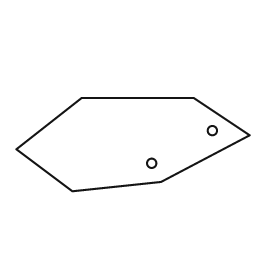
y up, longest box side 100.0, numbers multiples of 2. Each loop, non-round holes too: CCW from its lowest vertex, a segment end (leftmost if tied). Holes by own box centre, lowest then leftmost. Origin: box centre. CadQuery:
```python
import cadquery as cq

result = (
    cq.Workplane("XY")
    .moveTo(-26.0, -20.0)
    .lineTo(12.0, -16.0)
    .lineTo(50.0, 4.0)
    .lineTo(26.0, 20.0)
    .lineTo(-22.0, 20.0)
    .lineTo(-50.0, -2.0)
    .close()
    .moveTo(8.0, -8.0)
    .circle(2.0)
    .moveTo(34.0, 6.0)
    .circle(2.0)
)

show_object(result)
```